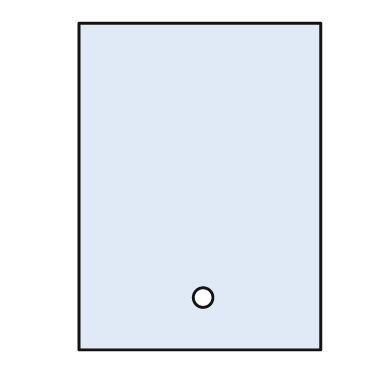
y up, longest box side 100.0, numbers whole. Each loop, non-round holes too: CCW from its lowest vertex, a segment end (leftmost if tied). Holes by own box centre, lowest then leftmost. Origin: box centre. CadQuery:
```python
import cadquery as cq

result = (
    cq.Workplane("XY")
    .moveTo(-37.0, -50.0)
    .lineTo(37.0, -50.0)
    .lineTo(37.0, 50.0)
    .lineTo(-37.0, 50.0)
    .close()
    .moveTo(1.0, -34.0)
    .circle(3.0)
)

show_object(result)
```